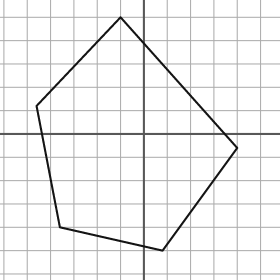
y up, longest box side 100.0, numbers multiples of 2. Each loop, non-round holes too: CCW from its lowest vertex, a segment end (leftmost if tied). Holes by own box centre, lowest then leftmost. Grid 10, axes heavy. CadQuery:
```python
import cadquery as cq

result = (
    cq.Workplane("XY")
    .moveTo(8.0, -50.0)
    .lineTo(40.0, -6.0)
    .lineTo(-10.0, 50.0)
    .lineTo(-46.0, 12.0)
    .lineTo(-36.0, -40.0)
    .close()
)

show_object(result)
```